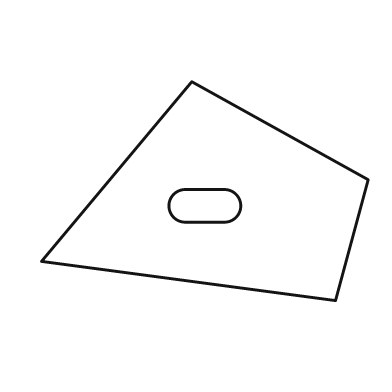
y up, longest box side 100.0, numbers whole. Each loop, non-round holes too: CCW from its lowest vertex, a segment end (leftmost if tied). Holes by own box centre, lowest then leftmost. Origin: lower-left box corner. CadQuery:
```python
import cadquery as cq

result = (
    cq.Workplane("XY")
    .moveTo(90.0, 0.0)
    .lineTo(100.0, 37.0)
    .lineTo(46.0, 67.0)
    .lineTo(0.0, 12.0)
    .close()
    .moveTo(44.0, 24.0)
    .lineTo(56.0, 24.0)
    .threePointArc((61.0, 29.0), (56.0, 34.0))
    .lineTo(44.0, 34.0)
    .threePointArc((39.0, 29.0), (44.0, 24.0))
    .close()
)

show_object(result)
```